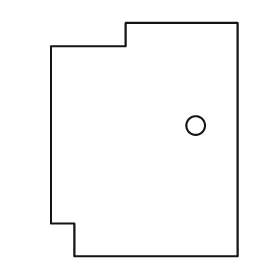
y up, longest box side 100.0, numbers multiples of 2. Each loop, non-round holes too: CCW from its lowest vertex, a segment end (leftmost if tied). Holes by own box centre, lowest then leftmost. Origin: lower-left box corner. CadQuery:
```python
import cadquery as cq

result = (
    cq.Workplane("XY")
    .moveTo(10.0, 0.0)
    .lineTo(80.0, 0.0)
    .lineTo(80.0, 100.0)
    .lineTo(32.0, 100.0)
    .lineTo(32.0, 90.0)
    .lineTo(0.0, 90.0)
    .lineTo(0.0, 14.0)
    .lineTo(10.0, 14.0)
    .close()
    .moveTo(62.0, 56.0)
    .circle(4.0)
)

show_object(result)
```